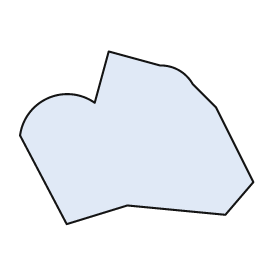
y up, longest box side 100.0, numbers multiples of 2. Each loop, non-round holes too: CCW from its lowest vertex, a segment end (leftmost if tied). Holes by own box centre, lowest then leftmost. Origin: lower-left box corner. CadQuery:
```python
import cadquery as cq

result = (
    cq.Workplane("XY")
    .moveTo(20.0, 0.0)
    .lineTo(46.0, 8.0)
    .lineTo(88.0, 4.0)
    .lineTo(100.0, 18.0)
    .lineTo(84.0, 50.0)
    .lineTo(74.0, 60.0)
    .threePointArc((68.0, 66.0), (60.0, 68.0))
    .lineTo(38.0, 74.0)
    .lineTo(32.0, 52.0)
    .threePointArc((12.0, 54.0), (0.0, 38.0))
    .close()
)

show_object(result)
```